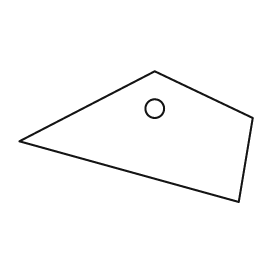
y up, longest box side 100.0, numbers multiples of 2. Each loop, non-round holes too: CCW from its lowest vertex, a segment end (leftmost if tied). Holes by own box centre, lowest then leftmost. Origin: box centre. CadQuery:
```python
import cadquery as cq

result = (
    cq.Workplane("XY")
    .moveTo(44.0, -28.0)
    .lineTo(50.0, 8.0)
    .lineTo(8.0, 28.0)
    .lineTo(-50.0, -2.0)
    .close()
    .moveTo(8.0, 12.0)
    .circle(4.0)
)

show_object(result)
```